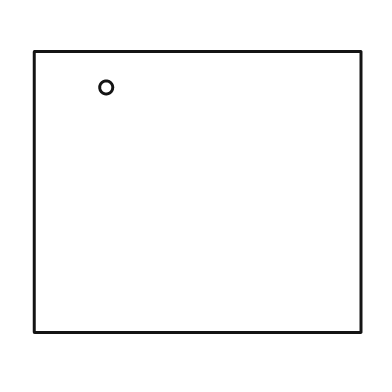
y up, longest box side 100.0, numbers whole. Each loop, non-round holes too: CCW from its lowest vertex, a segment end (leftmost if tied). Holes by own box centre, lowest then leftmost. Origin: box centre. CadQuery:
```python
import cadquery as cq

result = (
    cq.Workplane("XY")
    .moveTo(-50.0, -43.0)
    .lineTo(50.0, -43.0)
    .lineTo(50.0, 43.0)
    .lineTo(-50.0, 43.0)
    .close()
    .moveTo(-28.0, 32.0)
    .circle(2.0)
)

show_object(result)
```